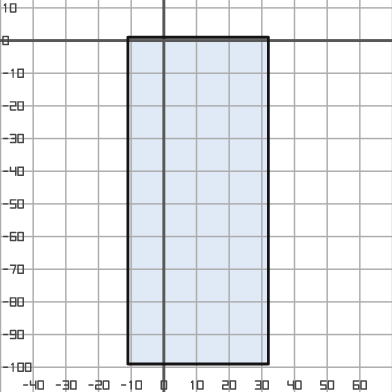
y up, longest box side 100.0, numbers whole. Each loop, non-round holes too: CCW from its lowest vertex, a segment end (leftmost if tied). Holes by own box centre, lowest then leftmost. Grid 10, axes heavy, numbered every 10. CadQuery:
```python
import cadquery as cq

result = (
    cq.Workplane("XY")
    .moveTo(-11.0, -99.0)
    .lineTo(32.0, -99.0)
    .lineTo(32.0, 1.0)
    .lineTo(-11.0, 1.0)
    .close()
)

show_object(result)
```